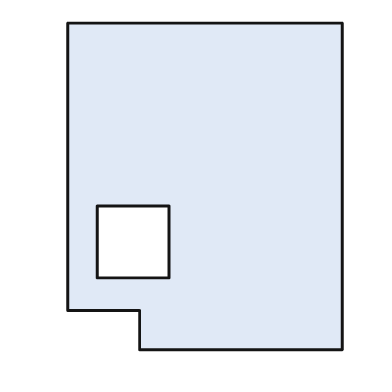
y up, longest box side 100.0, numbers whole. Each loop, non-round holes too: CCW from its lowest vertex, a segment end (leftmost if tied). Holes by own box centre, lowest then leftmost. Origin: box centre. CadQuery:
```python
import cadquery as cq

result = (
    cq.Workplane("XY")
    .moveTo(-20.0, -50.0)
    .lineTo(42.0, -50.0)
    .lineTo(42.0, 50.0)
    .lineTo(-42.0, 50.0)
    .lineTo(-42.0, -38.0)
    .lineTo(-20.0, -38.0)
    .close()
    .moveTo(-33.0, -28.0)
    .lineTo(-11.0, -28.0)
    .lineTo(-11.0, -6.0)
    .lineTo(-33.0, -6.0)
    .close()
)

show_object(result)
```